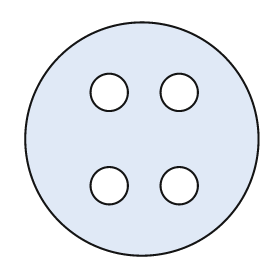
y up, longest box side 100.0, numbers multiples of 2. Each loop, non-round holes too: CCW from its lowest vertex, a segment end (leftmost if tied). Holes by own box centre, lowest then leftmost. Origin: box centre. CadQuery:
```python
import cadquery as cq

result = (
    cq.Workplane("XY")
    .moveTo(0.0, 0.0)
    .circle(50.0)
    .moveTo(-14.0, -20.0)
    .circle(8.0)
    .moveTo(16.0, -20.0)
    .circle(8.0)
    .moveTo(-14.0, 20.0)
    .circle(8.0)
    .moveTo(16.0, 20.0)
    .circle(8.0)
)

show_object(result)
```